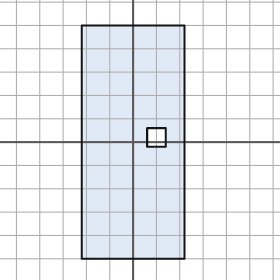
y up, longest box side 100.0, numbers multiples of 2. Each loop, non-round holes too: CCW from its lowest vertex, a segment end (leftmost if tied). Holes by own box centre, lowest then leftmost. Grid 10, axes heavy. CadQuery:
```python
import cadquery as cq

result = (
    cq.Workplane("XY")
    .moveTo(-22.0, -50.0)
    .lineTo(22.0, -50.0)
    .lineTo(22.0, 50.0)
    .lineTo(-22.0, 50.0)
    .close()
    .moveTo(6.0, -2.0)
    .lineTo(14.0, -2.0)
    .lineTo(14.0, 6.0)
    .lineTo(6.0, 6.0)
    .close()
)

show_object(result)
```